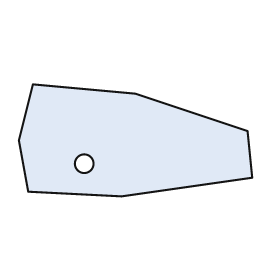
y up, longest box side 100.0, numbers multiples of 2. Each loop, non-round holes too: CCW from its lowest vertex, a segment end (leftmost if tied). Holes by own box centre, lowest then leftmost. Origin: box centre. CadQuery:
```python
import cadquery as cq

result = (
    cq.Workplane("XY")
    .moveTo(-6.0, -24.0)
    .lineTo(50.0, -16.0)
    .lineTo(48.0, 4.0)
    .lineTo(0.0, 20.0)
    .lineTo(-44.0, 24.0)
    .lineTo(-50.0, 0.0)
    .lineTo(-46.0, -22.0)
    .close()
    .moveTo(-22.0, -10.0)
    .circle(4.0)
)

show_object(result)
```